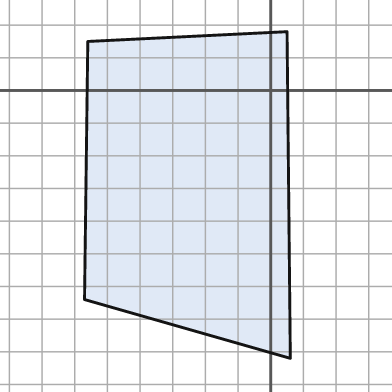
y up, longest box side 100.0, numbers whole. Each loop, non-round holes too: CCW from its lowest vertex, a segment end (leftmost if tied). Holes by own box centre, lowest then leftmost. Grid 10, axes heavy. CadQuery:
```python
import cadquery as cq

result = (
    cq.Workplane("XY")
    .moveTo(6.0, -82.0)
    .lineTo(5.0, 18.0)
    .lineTo(-56.0, 15.0)
    .lineTo(-57.0, -64.0)
    .close()
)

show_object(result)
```